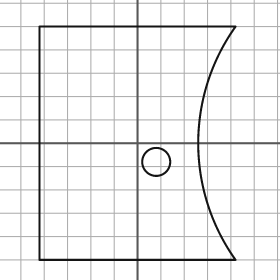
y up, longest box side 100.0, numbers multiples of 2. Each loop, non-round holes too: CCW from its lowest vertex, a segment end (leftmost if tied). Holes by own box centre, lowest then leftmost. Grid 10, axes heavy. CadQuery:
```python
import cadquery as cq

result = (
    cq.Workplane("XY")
    .moveTo(-42.0, -50.0)
    .lineTo(42.0, -50.0)
    .threePointArc((26.0, 0.0), (42.0, 50.0))
    .lineTo(-42.0, 50.0)
    .close()
    .moveTo(8.0, -8.0)
    .circle(6.0)
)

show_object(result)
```